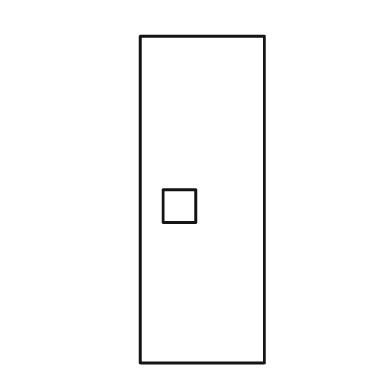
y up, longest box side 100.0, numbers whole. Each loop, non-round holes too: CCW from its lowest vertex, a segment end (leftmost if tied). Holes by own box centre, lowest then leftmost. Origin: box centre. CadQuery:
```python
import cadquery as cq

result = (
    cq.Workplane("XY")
    .moveTo(-19.0, -50.0)
    .lineTo(19.0, -50.0)
    .lineTo(19.0, 50.0)
    .lineTo(-19.0, 50.0)
    .close()
    .moveTo(-12.0, -7.0)
    .lineTo(-2.0, -7.0)
    .lineTo(-2.0, 3.0)
    .lineTo(-12.0, 3.0)
    .close()
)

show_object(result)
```